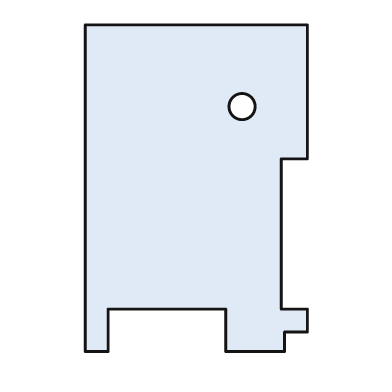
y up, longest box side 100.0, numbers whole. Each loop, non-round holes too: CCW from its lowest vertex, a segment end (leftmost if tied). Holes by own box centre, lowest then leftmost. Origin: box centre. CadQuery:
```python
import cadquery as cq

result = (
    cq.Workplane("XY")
    .moveTo(-34.0, -50.0)
    .lineTo(-27.0, -50.0)
    .lineTo(-27.0, -37.0)
    .lineTo(9.0, -37.0)
    .lineTo(9.0, -50.0)
    .lineTo(27.0, -50.0)
    .lineTo(27.0, -44.0)
    .lineTo(34.0, -44.0)
    .lineTo(34.0, -37.0)
    .lineTo(26.0, -37.0)
    .lineTo(26.0, 9.0)
    .lineTo(34.0, 9.0)
    .lineTo(34.0, 50.0)
    .lineTo(-34.0, 50.0)
    .close()
    .moveTo(14.0, 25.0)
    .circle(4.0)
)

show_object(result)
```